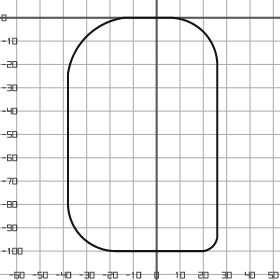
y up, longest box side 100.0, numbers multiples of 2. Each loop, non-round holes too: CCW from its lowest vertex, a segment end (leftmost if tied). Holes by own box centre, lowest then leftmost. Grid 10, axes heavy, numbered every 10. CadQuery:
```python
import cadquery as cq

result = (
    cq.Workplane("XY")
    .moveTo(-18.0, -100.0)
    .lineTo(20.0, -100.0)
    .threePointArc((24.0, -98.0), (26.0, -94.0))
    .lineTo(26.0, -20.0)
    .threePointArc((20.0, -6.0), (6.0, 0.0))
    .lineTo(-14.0, 0.0)
    .threePointArc((-30.0, -8.0), (-38.0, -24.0))
    .lineTo(-38.0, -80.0)
    .threePointArc((-32.0, -94.0), (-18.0, -100.0))
    .close()
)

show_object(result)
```